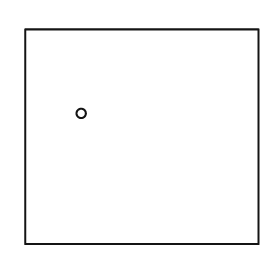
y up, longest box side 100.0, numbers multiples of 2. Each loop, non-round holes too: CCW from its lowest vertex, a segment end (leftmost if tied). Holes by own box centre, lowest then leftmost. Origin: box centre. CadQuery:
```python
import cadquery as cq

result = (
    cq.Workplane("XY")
    .moveTo(-50.0, -46.0)
    .lineTo(50.0, -46.0)
    .lineTo(50.0, 46.0)
    .lineTo(-50.0, 46.0)
    .close()
    .moveTo(-26.0, 10.0)
    .circle(2.0)
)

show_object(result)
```